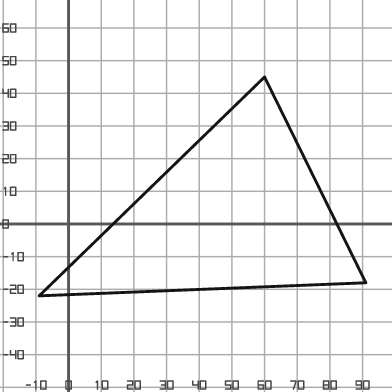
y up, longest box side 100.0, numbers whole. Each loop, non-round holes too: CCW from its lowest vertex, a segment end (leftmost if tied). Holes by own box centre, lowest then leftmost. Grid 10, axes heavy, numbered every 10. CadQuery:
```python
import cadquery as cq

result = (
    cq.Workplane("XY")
    .moveTo(-9.0, -22.0)
    .lineTo(91.0, -18.0)
    .lineTo(60.0, 45.0)
    .close()
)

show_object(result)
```